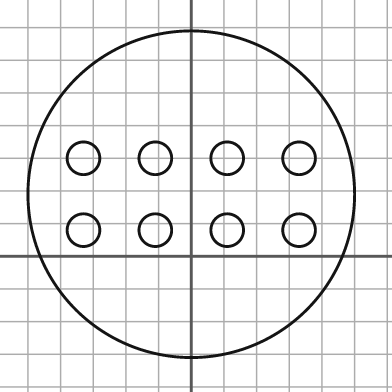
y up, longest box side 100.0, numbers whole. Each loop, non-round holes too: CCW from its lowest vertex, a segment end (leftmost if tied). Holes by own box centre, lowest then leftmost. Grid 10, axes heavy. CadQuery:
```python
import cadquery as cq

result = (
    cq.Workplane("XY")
    .moveTo(0.0, 19.0)
    .circle(50.0)
    .moveTo(-33.0, 8.0)
    .circle(5.0)
    .moveTo(-11.0, 8.0)
    .circle(5.0)
    .moveTo(11.0, 8.0)
    .circle(5.0)
    .moveTo(33.0, 8.0)
    .circle(5.0)
    .moveTo(-33.0, 30.0)
    .circle(5.0)
    .moveTo(-11.0, 30.0)
    .circle(5.0)
    .moveTo(11.0, 30.0)
    .circle(5.0)
    .moveTo(33.0, 30.0)
    .circle(5.0)
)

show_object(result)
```